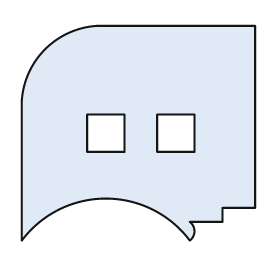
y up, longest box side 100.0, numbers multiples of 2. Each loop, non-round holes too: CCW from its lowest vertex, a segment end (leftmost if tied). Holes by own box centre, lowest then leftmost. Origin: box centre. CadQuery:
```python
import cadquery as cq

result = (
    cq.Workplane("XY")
    .moveTo(-50.0, -46.0)
    .threePointArc((-14.0, -28.0), (22.0, -46.0))
    .threePointArc((24.0, -42.0), (22.0, -38.0))
    .lineTo(36.0, -38.0)
    .lineTo(36.0, -32.0)
    .lineTo(50.0, -32.0)
    .lineTo(50.0, 46.0)
    .lineTo(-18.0, 46.0)
    .threePointArc((-40.0, 36.0), (-50.0, 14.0))
    .close()
    .moveTo(-22.0, -8.0)
    .lineTo(-6.0, -8.0)
    .lineTo(-6.0, 8.0)
    .lineTo(-22.0, 8.0)
    .close()
    .moveTo(8.0, -8.0)
    .lineTo(24.0, -8.0)
    .lineTo(24.0, 8.0)
    .lineTo(8.0, 8.0)
    .close()
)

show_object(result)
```